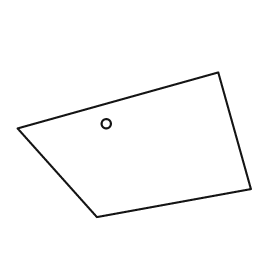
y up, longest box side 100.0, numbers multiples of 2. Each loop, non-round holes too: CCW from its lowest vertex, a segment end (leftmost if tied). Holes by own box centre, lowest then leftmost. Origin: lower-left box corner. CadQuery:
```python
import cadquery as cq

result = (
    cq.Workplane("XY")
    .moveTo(34.0, 0.0)
    .lineTo(100.0, 12.0)
    .lineTo(86.0, 62.0)
    .lineTo(0.0, 38.0)
    .close()
    .moveTo(38.0, 40.0)
    .circle(2.0)
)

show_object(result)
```